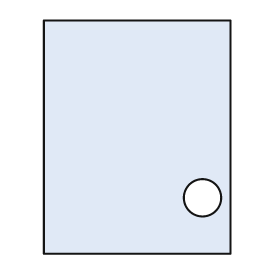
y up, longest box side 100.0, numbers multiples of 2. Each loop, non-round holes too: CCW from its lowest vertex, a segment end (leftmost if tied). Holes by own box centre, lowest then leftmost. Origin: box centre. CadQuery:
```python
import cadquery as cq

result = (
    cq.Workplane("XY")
    .moveTo(-40.0, -50.0)
    .lineTo(40.0, -50.0)
    .lineTo(40.0, 50.0)
    .lineTo(-40.0, 50.0)
    .close()
    .moveTo(28.0, -26.0)
    .circle(8.0)
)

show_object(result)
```